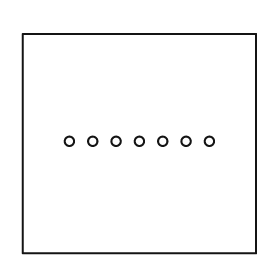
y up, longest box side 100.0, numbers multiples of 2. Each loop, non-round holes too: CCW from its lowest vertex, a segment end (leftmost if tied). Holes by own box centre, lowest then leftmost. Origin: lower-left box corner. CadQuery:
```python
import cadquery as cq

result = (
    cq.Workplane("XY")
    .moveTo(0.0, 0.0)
    .lineTo(100.0, 0.0)
    .lineTo(100.0, 94.0)
    .lineTo(0.0, 94.0)
    .close()
    .moveTo(20.0, 48.0)
    .circle(2.0)
    .moveTo(30.0, 48.0)
    .circle(2.0)
    .moveTo(40.0, 48.0)
    .circle(2.0)
    .moveTo(50.0, 48.0)
    .circle(2.0)
    .moveTo(60.0, 48.0)
    .circle(2.0)
    .moveTo(70.0, 48.0)
    .circle(2.0)
    .moveTo(80.0, 48.0)
    .circle(2.0)
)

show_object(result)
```